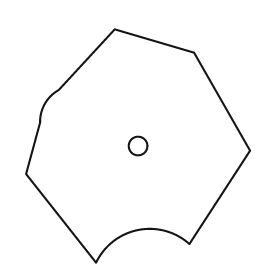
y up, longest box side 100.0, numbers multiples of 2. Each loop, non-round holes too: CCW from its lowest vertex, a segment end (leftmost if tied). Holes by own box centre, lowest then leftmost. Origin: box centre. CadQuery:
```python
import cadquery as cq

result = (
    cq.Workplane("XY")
    .moveTo(-18.0, -50.0)
    .threePointArc((0.0, -36.0), (22.0, -42.0))
    .lineTo(48.0, -2.0)
    .lineTo(24.0, 40.0)
    .lineTo(-10.0, 50.0)
    .lineTo(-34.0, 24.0)
    .threePointArc((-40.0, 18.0), (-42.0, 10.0))
    .lineTo(-48.0, -12.0)
    .close()
    .moveTo(0.0, 0.0)
    .circle(4.0)
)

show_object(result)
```